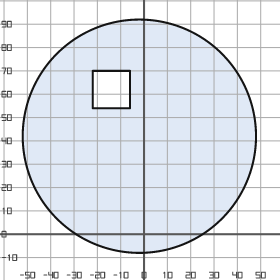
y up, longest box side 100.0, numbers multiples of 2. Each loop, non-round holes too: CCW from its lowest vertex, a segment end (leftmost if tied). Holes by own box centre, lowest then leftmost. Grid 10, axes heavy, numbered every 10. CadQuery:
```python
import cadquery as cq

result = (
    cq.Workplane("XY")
    .moveTo(-2.0, 42.0)
    .circle(50.0)
    .moveTo(-22.0, 54.0)
    .lineTo(-6.0, 54.0)
    .lineTo(-6.0, 70.0)
    .lineTo(-22.0, 70.0)
    .close()
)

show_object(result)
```